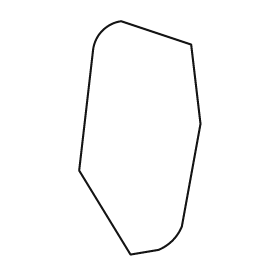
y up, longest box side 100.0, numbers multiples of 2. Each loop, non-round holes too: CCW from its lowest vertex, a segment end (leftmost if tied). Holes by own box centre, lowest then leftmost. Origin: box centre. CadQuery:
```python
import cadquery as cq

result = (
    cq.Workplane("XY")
    .moveTo(-4.0, -50.0)
    .lineTo(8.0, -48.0)
    .threePointArc((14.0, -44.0), (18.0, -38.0))
    .lineTo(26.0, 6.0)
    .lineTo(22.0, 40.0)
    .lineTo(-8.0, 50.0)
    .threePointArc((-16.0, 46.0), (-20.0, 38.0))
    .lineTo(-26.0, -14.0)
    .close()
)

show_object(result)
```